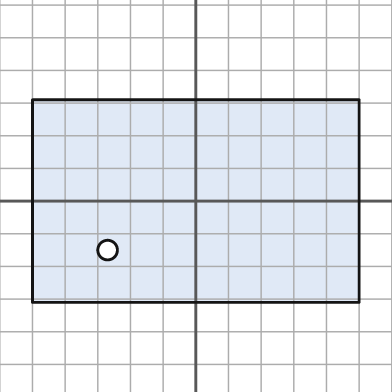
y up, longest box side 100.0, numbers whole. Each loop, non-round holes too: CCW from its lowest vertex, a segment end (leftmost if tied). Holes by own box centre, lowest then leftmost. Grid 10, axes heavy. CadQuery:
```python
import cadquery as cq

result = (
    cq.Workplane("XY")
    .moveTo(-50.0, -31.0)
    .lineTo(50.0, -31.0)
    .lineTo(50.0, 31.0)
    .lineTo(-50.0, 31.0)
    .close()
    .moveTo(-27.0, -15.0)
    .circle(3.0)
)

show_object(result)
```